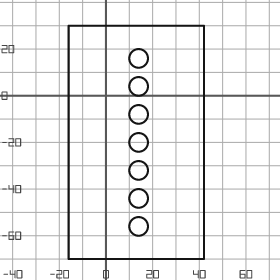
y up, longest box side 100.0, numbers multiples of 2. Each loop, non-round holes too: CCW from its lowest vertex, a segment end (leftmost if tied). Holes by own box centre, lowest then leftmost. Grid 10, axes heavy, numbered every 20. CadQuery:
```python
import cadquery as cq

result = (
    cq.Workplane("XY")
    .moveTo(-16.0, -70.0)
    .lineTo(42.0, -70.0)
    .lineTo(42.0, 30.0)
    .lineTo(-16.0, 30.0)
    .close()
    .moveTo(14.0, -56.0)
    .circle(4.0)
    .moveTo(14.0, -44.0)
    .circle(4.0)
    .moveTo(14.0, -32.0)
    .circle(4.0)
    .moveTo(14.0, -20.0)
    .circle(4.0)
    .moveTo(14.0, -8.0)
    .circle(4.0)
    .moveTo(14.0, 4.0)
    .circle(4.0)
    .moveTo(14.0, 16.0)
    .circle(4.0)
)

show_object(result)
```